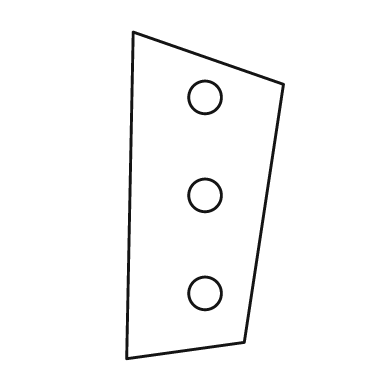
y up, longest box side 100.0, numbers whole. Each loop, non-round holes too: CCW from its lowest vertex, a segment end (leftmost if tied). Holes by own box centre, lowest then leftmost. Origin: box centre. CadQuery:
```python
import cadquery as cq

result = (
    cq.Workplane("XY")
    .moveTo(-24.0, -50.0)
    .lineTo(12.0, -45.0)
    .lineTo(24.0, 34.0)
    .lineTo(-22.0, 50.0)
    .close()
    .moveTo(0.0, -30.0)
    .circle(5.0)
    .moveTo(0.0, 0.0)
    .circle(5.0)
    .moveTo(0.0, 30.0)
    .circle(5.0)
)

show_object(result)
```